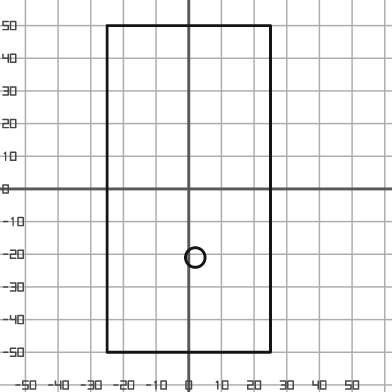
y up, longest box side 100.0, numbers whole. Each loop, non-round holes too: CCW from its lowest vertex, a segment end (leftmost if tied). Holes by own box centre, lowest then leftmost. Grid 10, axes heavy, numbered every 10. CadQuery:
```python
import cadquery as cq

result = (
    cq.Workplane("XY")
    .moveTo(-25.0, -50.0)
    .lineTo(25.0, -50.0)
    .lineTo(25.0, 50.0)
    .lineTo(-25.0, 50.0)
    .close()
    .moveTo(2.0, -21.0)
    .circle(3.0)
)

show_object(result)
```